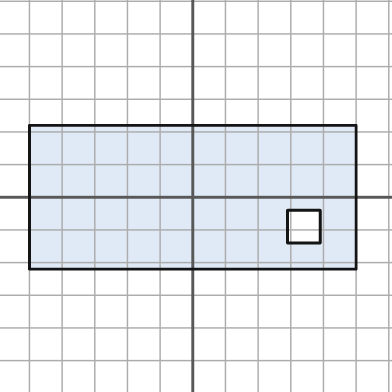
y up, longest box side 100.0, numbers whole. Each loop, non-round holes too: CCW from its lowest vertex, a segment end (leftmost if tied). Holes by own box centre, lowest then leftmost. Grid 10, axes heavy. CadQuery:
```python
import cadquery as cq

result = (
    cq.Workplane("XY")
    .moveTo(-50.0, -22.0)
    .lineTo(50.0, -22.0)
    .lineTo(50.0, 22.0)
    .lineTo(-50.0, 22.0)
    .close()
    .moveTo(29.0, -14.0)
    .lineTo(39.0, -14.0)
    .lineTo(39.0, -4.0)
    .lineTo(29.0, -4.0)
    .close()
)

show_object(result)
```